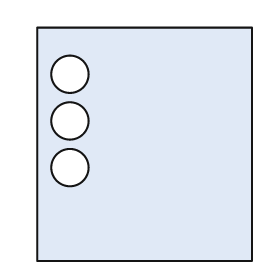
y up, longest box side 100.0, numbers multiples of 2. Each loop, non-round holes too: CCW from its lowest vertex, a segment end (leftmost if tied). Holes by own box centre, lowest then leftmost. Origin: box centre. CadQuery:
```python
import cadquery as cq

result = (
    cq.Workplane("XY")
    .moveTo(-46.0, -50.0)
    .lineTo(46.0, -50.0)
    .lineTo(46.0, 50.0)
    .lineTo(-46.0, 50.0)
    .close()
    .moveTo(-32.0, -10.0)
    .circle(8.0)
    .moveTo(-32.0, 10.0)
    .circle(8.0)
    .moveTo(-32.0, 30.0)
    .circle(8.0)
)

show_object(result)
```